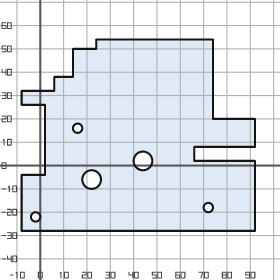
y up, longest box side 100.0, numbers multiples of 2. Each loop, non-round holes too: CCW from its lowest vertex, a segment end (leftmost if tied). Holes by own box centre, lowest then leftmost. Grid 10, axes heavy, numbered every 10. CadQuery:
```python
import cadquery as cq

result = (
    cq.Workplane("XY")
    .moveTo(-8.0, -28.0)
    .lineTo(92.0, -28.0)
    .lineTo(92.0, 2.0)
    .lineTo(66.0, 2.0)
    .lineTo(66.0, 8.0)
    .lineTo(92.0, 8.0)
    .lineTo(92.0, 20.0)
    .lineTo(74.0, 20.0)
    .lineTo(74.0, 54.0)
    .lineTo(24.0, 54.0)
    .lineTo(24.0, 50.0)
    .lineTo(14.0, 50.0)
    .lineTo(14.0, 38.0)
    .lineTo(6.0, 38.0)
    .lineTo(6.0, 32.0)
    .lineTo(-8.0, 32.0)
    .lineTo(-8.0, 26.0)
    .lineTo(2.0, 26.0)
    .lineTo(2.0, -4.0)
    .lineTo(-8.0, -4.0)
    .close()
    .moveTo(-2.0, -22.0)
    .circle(2.0)
    .moveTo(72.0, -18.0)
    .circle(2.0)
    .moveTo(22.0, -6.0)
    .circle(4.0)
    .moveTo(44.0, 2.0)
    .circle(4.0)
    .moveTo(16.0, 16.0)
    .circle(2.0)
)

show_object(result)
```